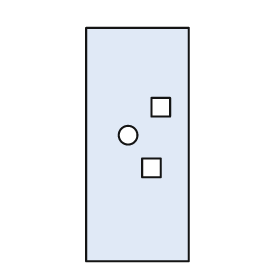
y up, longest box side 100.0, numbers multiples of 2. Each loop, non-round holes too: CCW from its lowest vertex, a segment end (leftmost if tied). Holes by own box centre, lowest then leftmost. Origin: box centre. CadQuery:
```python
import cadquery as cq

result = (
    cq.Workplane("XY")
    .moveTo(-22.0, -50.0)
    .lineTo(22.0, -50.0)
    .lineTo(22.0, 50.0)
    .lineTo(-22.0, 50.0)
    .close()
    .moveTo(2.0, -14.0)
    .lineTo(10.0, -14.0)
    .lineTo(10.0, -6.0)
    .lineTo(2.0, -6.0)
    .close()
    .moveTo(-4.0, 4.0)
    .circle(4.0)
    .moveTo(6.0, 12.0)
    .lineTo(14.0, 12.0)
    .lineTo(14.0, 20.0)
    .lineTo(6.0, 20.0)
    .close()
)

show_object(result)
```